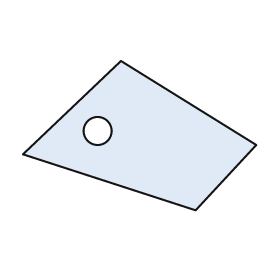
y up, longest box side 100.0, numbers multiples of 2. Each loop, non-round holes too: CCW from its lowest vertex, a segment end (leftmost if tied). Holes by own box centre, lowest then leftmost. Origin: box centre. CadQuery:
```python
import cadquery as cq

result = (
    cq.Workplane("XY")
    .moveTo(24.0, -32.0)
    .lineTo(50.0, -4.0)
    .lineTo(-8.0, 32.0)
    .lineTo(-50.0, -8.0)
    .close()
    .moveTo(-18.0, 2.0)
    .circle(6.0)
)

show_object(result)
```